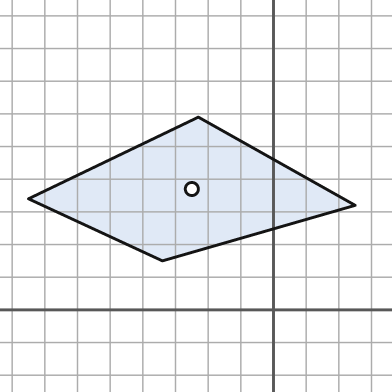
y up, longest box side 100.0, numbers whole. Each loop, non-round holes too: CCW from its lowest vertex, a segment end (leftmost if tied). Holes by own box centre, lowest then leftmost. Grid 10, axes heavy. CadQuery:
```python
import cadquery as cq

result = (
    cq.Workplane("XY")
    .moveTo(-34.0, 15.0)
    .lineTo(25.0, 32.0)
    .lineTo(-23.0, 59.0)
    .lineTo(-75.0, 34.0)
    .close()
    .moveTo(-25.0, 37.0)
    .circle(2.0)
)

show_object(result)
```